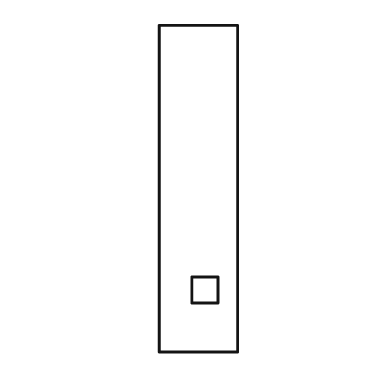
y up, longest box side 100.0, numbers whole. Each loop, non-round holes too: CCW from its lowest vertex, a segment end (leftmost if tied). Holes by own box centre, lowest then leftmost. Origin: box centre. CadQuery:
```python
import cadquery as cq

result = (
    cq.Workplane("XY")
    .moveTo(-12.0, -50.0)
    .lineTo(12.0, -50.0)
    .lineTo(12.0, 50.0)
    .lineTo(-12.0, 50.0)
    .close()
    .moveTo(-2.0, -35.0)
    .lineTo(6.0, -35.0)
    .lineTo(6.0, -27.0)
    .lineTo(-2.0, -27.0)
    .close()
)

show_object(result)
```